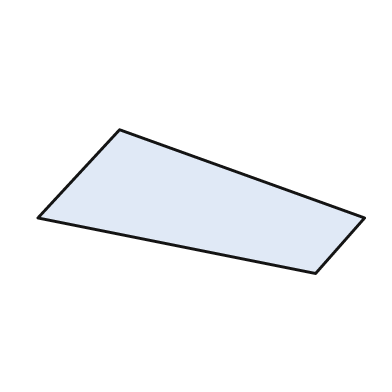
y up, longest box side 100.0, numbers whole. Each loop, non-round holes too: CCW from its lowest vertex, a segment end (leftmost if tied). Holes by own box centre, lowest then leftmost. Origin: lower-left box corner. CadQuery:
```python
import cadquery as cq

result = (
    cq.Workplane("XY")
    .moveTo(85.0, 0.0)
    .lineTo(100.0, 17.0)
    .lineTo(25.0, 44.0)
    .lineTo(0.0, 17.0)
    .close()
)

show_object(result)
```